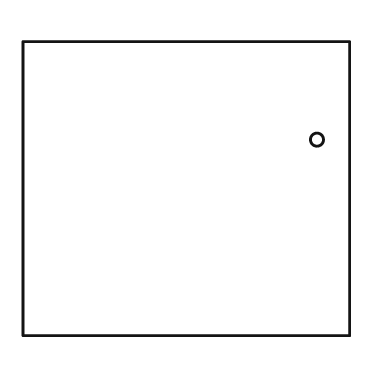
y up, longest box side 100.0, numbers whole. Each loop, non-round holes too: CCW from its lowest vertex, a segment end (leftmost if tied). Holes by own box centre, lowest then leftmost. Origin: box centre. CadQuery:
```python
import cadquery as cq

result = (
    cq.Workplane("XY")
    .moveTo(-50.0, -45.0)
    .lineTo(50.0, -45.0)
    .lineTo(50.0, 45.0)
    .lineTo(-50.0, 45.0)
    .close()
    .moveTo(40.0, 15.0)
    .circle(2.0)
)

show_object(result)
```